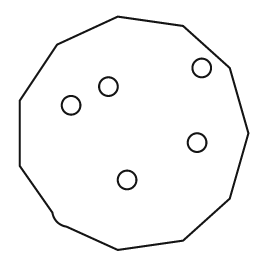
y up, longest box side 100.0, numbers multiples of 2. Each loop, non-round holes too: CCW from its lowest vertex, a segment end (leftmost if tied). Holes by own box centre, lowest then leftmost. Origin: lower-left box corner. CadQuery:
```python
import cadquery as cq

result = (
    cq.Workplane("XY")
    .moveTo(42.0, 0.0)
    .lineTo(70.0, 4.0)
    .lineTo(90.0, 22.0)
    .lineTo(98.0, 50.0)
    .lineTo(90.0, 78.0)
    .lineTo(70.0, 96.0)
    .lineTo(42.0, 100.0)
    .lineTo(16.0, 88.0)
    .lineTo(0.0, 64.0)
    .lineTo(0.0, 36.0)
    .lineTo(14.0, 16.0)
    .threePointArc((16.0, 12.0), (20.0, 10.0))
    .close()
    .moveTo(46.0, 30.0)
    .circle(4.0)
    .moveTo(76.0, 46.0)
    .circle(4.0)
    .moveTo(22.0, 62.0)
    .circle(4.0)
    .moveTo(38.0, 70.0)
    .circle(4.0)
    .moveTo(78.0, 78.0)
    .circle(4.0)
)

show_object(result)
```